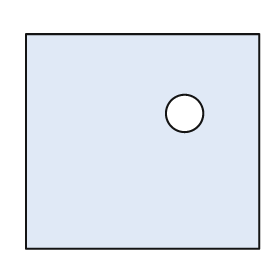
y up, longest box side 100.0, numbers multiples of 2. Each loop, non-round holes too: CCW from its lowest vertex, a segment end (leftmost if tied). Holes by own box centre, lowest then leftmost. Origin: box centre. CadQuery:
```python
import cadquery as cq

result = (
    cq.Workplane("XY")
    .moveTo(-50.0, -46.0)
    .lineTo(50.0, -46.0)
    .lineTo(50.0, 46.0)
    .lineTo(-50.0, 46.0)
    .close()
    .moveTo(18.0, 12.0)
    .circle(8.0)
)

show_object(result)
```